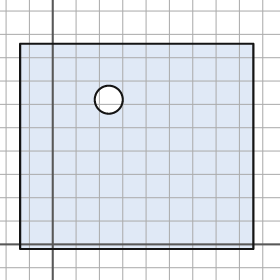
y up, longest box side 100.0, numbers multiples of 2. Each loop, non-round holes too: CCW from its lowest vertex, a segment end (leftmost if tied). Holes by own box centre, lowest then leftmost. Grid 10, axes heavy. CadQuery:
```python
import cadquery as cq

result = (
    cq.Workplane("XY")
    .moveTo(-14.0, -2.0)
    .lineTo(86.0, -2.0)
    .lineTo(86.0, 86.0)
    .lineTo(-14.0, 86.0)
    .close()
    .moveTo(24.0, 62.0)
    .circle(6.0)
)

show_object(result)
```